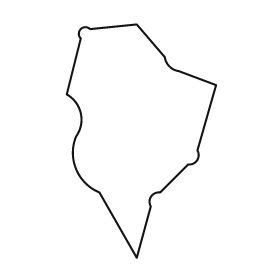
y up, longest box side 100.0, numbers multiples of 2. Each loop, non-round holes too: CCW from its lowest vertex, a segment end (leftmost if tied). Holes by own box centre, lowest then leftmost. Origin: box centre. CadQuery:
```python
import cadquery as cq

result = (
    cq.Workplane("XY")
    .moveTo(-2.0, -50.0)
    .lineTo(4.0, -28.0)
    .threePointArc((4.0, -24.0), (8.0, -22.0))
    .lineTo(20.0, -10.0)
    .threePointArc((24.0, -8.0), (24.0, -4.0))
    .lineTo(32.0, 24.0)
    .lineTo(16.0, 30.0)
    .threePointArc((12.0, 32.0), (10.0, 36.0))
    .lineTo(-2.0, 50.0)
    .lineTo(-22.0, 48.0)
    .threePointArc((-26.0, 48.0), (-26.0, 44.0))
    .lineTo(-32.0, 20.0)
    .threePointArc((-26.0, 12.0), (-28.0, 2.0))
    .threePointArc((-28.0, -12.0), (-18.0, -22.0))
    .close()
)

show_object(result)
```